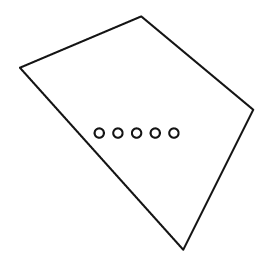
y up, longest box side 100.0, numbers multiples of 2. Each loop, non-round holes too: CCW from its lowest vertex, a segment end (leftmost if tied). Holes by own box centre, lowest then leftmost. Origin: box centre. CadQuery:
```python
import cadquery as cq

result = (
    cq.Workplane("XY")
    .moveTo(20.0, -50.0)
    .lineTo(50.0, 10.0)
    .lineTo(2.0, 50.0)
    .lineTo(-50.0, 28.0)
    .close()
    .moveTo(-16.0, 0.0)
    .circle(2.0)
    .moveTo(-8.0, 0.0)
    .circle(2.0)
    .moveTo(0.0, 0.0)
    .circle(2.0)
    .moveTo(8.0, 0.0)
    .circle(2.0)
    .moveTo(16.0, 0.0)
    .circle(2.0)
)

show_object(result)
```